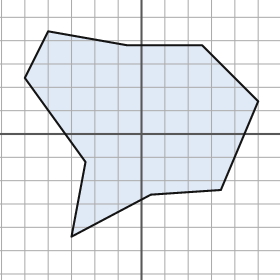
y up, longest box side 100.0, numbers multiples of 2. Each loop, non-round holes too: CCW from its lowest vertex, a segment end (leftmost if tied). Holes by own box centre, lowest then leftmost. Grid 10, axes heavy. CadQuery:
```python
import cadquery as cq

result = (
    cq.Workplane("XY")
    .moveTo(-30.0, -44.0)
    .lineTo(4.0, -26.0)
    .lineTo(34.0, -24.0)
    .lineTo(50.0, 14.0)
    .lineTo(26.0, 38.0)
    .lineTo(-6.0, 38.0)
    .lineTo(-40.0, 44.0)
    .lineTo(-50.0, 24.0)
    .lineTo(-24.0, -12.0)
    .close()
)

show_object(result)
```